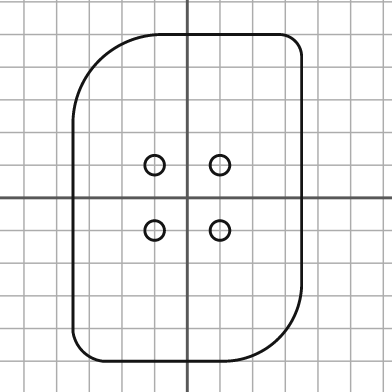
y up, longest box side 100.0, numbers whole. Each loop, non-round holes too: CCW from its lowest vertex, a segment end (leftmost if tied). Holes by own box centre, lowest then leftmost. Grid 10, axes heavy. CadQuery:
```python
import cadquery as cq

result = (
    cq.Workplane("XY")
    .moveTo(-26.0, -50.0)
    .lineTo(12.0, -50.0)
    .threePointArc((28.0, -43.0), (35.0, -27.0))
    .lineTo(35.0, 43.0)
    .threePointArc((33.0, 48.0), (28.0, 50.0))
    .lineTo(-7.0, 50.0)
    .threePointArc((-27.0, 42.0), (-35.0, 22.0))
    .lineTo(-35.0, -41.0)
    .threePointArc((-32.0, -47.0), (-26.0, -50.0))
    .close()
    .moveTo(-10.0, -10.0)
    .circle(3.0)
    .moveTo(10.0, -10.0)
    .circle(3.0)
    .moveTo(-10.0, 10.0)
    .circle(3.0)
    .moveTo(10.0, 10.0)
    .circle(3.0)
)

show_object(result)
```